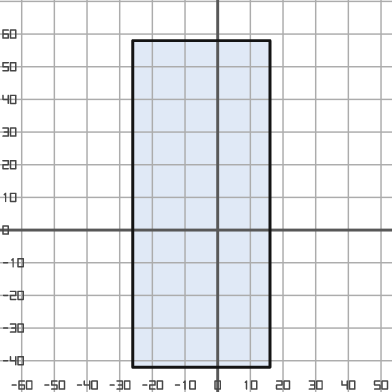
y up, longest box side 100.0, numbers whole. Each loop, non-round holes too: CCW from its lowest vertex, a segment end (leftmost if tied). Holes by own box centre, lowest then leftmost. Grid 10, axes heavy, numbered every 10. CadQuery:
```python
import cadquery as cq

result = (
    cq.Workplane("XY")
    .moveTo(-26.0, -42.0)
    .lineTo(16.0, -42.0)
    .lineTo(16.0, 58.0)
    .lineTo(-26.0, 58.0)
    .close()
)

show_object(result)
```